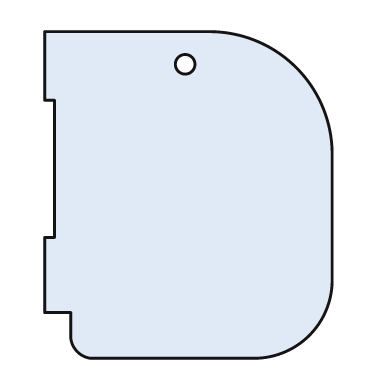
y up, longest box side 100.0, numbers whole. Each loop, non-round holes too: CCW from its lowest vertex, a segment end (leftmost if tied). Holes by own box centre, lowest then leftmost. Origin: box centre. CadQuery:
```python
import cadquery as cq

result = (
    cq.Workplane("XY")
    .moveTo(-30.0, -50.0)
    .lineTo(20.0, -50.0)
    .threePointArc((37.0, -43.0), (44.0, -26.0))
    .lineTo(44.0, 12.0)
    .threePointArc((33.0, 39.0), (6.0, 50.0))
    .lineTo(-44.0, 50.0)
    .lineTo(-44.0, 29.0)
    .lineTo(-41.0, 29.0)
    .lineTo(-41.0, -13.0)
    .lineTo(-44.0, -13.0)
    .lineTo(-44.0, -36.0)
    .lineTo(-36.0, -36.0)
    .lineTo(-36.0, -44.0)
    .threePointArc((-34.0, -48.0), (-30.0, -50.0))
    .close()
    .moveTo(-1.0, 40.0)
    .circle(3.0)
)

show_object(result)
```